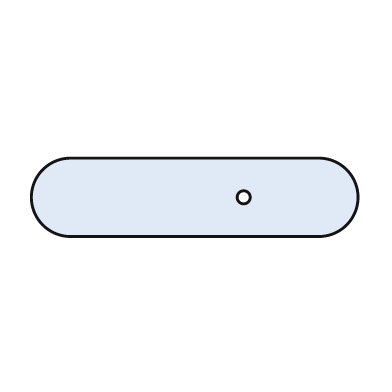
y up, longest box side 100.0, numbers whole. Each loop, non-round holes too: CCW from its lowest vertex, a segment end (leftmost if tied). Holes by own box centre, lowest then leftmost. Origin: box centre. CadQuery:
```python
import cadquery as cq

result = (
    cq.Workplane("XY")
    .moveTo(-38.0, -12.0)
    .lineTo(38.0, -12.0)
    .threePointArc((50.0, 0.0), (38.0, 12.0))
    .lineTo(-38.0, 12.0)
    .threePointArc((-50.0, 0.0), (-38.0, -12.0))
    .close()
    .moveTo(15.0, 0.0)
    .circle(2.0)
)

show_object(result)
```